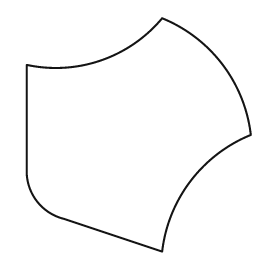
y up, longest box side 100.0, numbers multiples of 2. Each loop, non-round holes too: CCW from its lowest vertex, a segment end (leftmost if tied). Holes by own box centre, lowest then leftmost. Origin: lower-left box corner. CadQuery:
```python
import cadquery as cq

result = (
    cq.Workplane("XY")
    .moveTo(58.0, 0.0)
    .threePointArc((70.0, 30.0), (96.0, 50.0))
    .threePointArc((84.0, 80.0), (58.0, 100.0))
    .threePointArc((32.0, 82.0), (0.0, 80.0))
    .lineTo(0.0, 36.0)
    .threePointArc((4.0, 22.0), (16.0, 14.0))
    .close()
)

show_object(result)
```